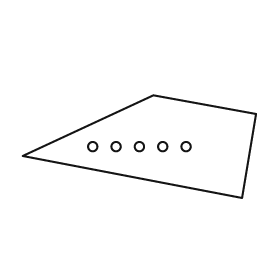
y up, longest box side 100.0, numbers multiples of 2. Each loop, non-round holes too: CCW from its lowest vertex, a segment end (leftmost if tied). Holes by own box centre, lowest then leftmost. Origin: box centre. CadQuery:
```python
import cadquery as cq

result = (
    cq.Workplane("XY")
    .moveTo(44.0, -22.0)
    .lineTo(50.0, 14.0)
    .lineTo(6.0, 22.0)
    .lineTo(-50.0, -4.0)
    .close()
    .moveTo(-20.0, 0.0)
    .circle(2.0)
    .moveTo(-10.0, 0.0)
    .circle(2.0)
    .moveTo(0.0, 0.0)
    .circle(2.0)
    .moveTo(10.0, 0.0)
    .circle(2.0)
    .moveTo(20.0, 0.0)
    .circle(2.0)
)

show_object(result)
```